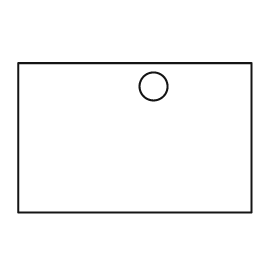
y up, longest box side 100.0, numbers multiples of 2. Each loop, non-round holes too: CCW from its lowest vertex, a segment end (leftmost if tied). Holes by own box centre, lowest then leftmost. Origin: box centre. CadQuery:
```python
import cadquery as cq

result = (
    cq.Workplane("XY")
    .moveTo(-50.0, -32.0)
    .lineTo(50.0, -32.0)
    .lineTo(50.0, 32.0)
    .lineTo(-50.0, 32.0)
    .close()
    .moveTo(8.0, 22.0)
    .circle(6.0)
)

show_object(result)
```